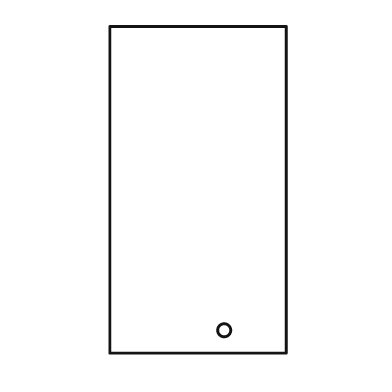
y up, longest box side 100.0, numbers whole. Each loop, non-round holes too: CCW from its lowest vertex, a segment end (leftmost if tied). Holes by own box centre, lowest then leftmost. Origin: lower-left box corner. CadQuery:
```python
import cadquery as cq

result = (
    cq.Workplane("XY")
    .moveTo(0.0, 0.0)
    .lineTo(54.0, 0.0)
    .lineTo(54.0, 100.0)
    .lineTo(0.0, 100.0)
    .close()
    .moveTo(35.0, 7.0)
    .circle(2.0)
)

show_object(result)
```